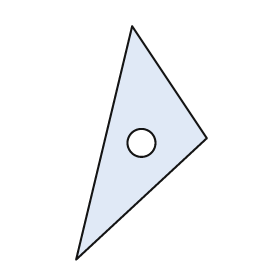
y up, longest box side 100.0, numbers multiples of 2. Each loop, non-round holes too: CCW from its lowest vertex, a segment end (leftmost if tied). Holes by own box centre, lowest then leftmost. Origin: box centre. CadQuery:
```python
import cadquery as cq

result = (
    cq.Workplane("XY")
    .moveTo(-28.0, -50.0)
    .lineTo(28.0, 2.0)
    .lineTo(-4.0, 50.0)
    .close()
    .moveTo(0.0, 0.0)
    .circle(6.0)
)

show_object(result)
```